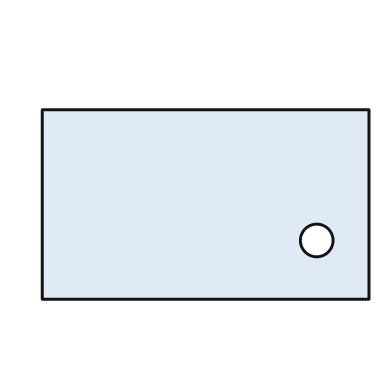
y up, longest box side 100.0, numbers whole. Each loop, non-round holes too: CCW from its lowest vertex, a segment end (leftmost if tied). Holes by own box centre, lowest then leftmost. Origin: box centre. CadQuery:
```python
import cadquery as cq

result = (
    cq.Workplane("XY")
    .moveTo(-50.0, -29.0)
    .lineTo(50.0, -29.0)
    .lineTo(50.0, 29.0)
    .lineTo(-50.0, 29.0)
    .close()
    .moveTo(34.0, -11.0)
    .circle(5.0)
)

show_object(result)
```